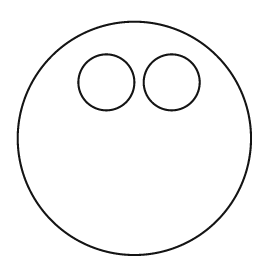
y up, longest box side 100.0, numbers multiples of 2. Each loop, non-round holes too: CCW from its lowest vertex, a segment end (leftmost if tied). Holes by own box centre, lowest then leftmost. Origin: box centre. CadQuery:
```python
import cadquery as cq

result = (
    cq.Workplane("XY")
    .moveTo(0.0, 0.0)
    .circle(50.0)
    .moveTo(-12.0, 24.0)
    .circle(12.0)
    .moveTo(16.0, 24.0)
    .circle(12.0)
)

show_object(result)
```